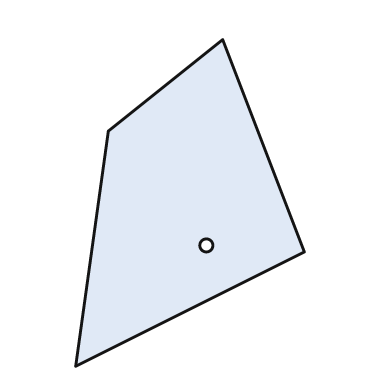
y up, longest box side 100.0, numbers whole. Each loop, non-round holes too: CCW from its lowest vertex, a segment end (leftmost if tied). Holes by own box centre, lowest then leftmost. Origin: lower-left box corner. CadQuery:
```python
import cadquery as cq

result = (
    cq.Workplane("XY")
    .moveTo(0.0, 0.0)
    .lineTo(70.0, 35.0)
    .lineTo(45.0, 100.0)
    .lineTo(10.0, 72.0)
    .close()
    .moveTo(40.0, 37.0)
    .circle(2.0)
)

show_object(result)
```